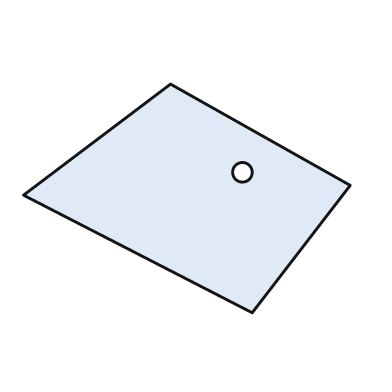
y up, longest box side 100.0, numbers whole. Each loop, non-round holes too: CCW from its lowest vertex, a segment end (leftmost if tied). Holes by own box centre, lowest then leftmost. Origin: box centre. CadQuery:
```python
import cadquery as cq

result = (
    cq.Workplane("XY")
    .moveTo(20.0, -35.0)
    .lineTo(50.0, 4.0)
    .lineTo(-5.0, 35.0)
    .lineTo(-50.0, 1.0)
    .close()
    .moveTo(17.0, 8.0)
    .circle(3.0)
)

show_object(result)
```